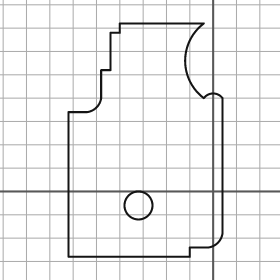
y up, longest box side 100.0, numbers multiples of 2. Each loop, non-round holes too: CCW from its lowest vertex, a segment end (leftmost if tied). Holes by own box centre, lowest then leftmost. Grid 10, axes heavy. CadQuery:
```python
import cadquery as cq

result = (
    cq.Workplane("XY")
    .moveTo(-62.0, -28.0)
    .lineTo(-10.0, -28.0)
    .lineTo(-10.0, -24.0)
    .lineTo(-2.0, -24.0)
    .threePointArc((2.0, -22.0), (4.0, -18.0))
    .lineTo(4.0, 40.0)
    .threePointArc((0.0, 42.0), (-4.0, 40.0))
    .threePointArc((-12.0, 56.0), (-4.0, 72.0))
    .lineTo(-40.0, 72.0)
    .lineTo(-40.0, 68.0)
    .lineTo(-44.0, 68.0)
    .lineTo(-44.0, 52.0)
    .lineTo(-48.0, 52.0)
    .lineTo(-48.0, 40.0)
    .threePointArc((-50.0, 36.0), (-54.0, 34.0))
    .lineTo(-62.0, 34.0)
    .close()
    .moveTo(-32.0, -6.0)
    .circle(6.0)
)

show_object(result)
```